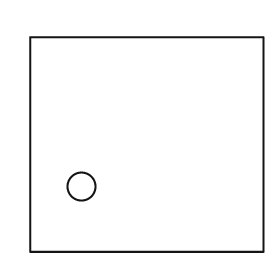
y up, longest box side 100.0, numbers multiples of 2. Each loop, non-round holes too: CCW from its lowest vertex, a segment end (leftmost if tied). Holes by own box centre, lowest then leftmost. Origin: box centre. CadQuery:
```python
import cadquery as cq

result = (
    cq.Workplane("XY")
    .moveTo(-50.0, -46.0)
    .lineTo(50.0, -46.0)
    .lineTo(50.0, 46.0)
    .lineTo(-50.0, 46.0)
    .close()
    .moveTo(-28.0, -18.0)
    .circle(6.0)
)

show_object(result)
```